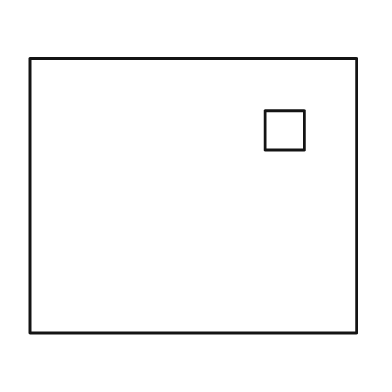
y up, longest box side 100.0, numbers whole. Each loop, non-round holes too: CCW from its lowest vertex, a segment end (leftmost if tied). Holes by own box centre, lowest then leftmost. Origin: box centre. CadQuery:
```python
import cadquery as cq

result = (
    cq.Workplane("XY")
    .moveTo(-50.0, -42.0)
    .lineTo(50.0, -42.0)
    .lineTo(50.0, 42.0)
    .lineTo(-50.0, 42.0)
    .close()
    .moveTo(22.0, 14.0)
    .lineTo(34.0, 14.0)
    .lineTo(34.0, 26.0)
    .lineTo(22.0, 26.0)
    .close()
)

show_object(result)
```